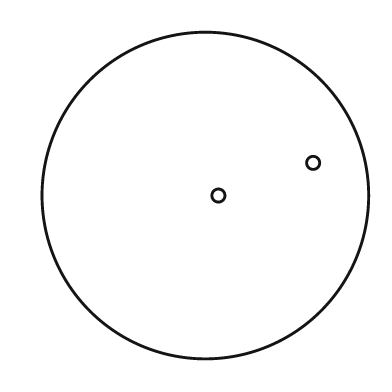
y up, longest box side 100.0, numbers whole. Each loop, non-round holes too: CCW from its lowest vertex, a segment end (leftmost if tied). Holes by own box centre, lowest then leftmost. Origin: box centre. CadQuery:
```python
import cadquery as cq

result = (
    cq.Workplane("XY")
    .moveTo(0.0, 0.0)
    .circle(50.0)
    .moveTo(4.0, 0.0)
    .circle(2.0)
    .moveTo(33.0, 10.0)
    .circle(2.0)
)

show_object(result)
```